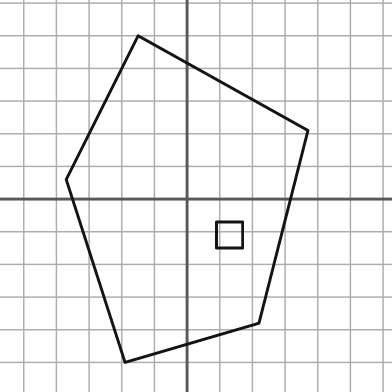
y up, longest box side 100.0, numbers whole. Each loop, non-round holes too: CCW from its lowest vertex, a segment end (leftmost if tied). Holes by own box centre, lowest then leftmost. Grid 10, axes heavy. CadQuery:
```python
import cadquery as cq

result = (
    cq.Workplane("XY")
    .moveTo(-19.0, -50.0)
    .lineTo(22.0, -38.0)
    .lineTo(37.0, 21.0)
    .lineTo(-15.0, 50.0)
    .lineTo(-37.0, 6.0)
    .close()
    .moveTo(9.0, -15.0)
    .lineTo(17.0, -15.0)
    .lineTo(17.0, -7.0)
    .lineTo(9.0, -7.0)
    .close()
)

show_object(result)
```